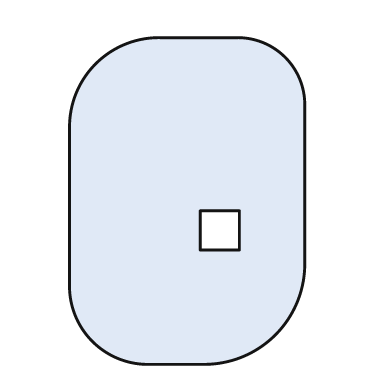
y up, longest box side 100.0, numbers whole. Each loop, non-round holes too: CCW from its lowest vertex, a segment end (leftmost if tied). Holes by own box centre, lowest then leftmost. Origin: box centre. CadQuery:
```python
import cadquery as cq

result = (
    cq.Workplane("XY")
    .moveTo(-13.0, -50.0)
    .lineTo(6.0, -50.0)
    .threePointArc((27.0, -41.0), (36.0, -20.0))
    .lineTo(36.0, 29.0)
    .threePointArc((30.0, 44.0), (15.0, 50.0))
    .lineTo(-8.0, 50.0)
    .threePointArc((-28.0, 42.0), (-36.0, 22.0))
    .lineTo(-36.0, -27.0)
    .threePointArc((-29.0, -43.0), (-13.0, -50.0))
    .close()
    .moveTo(4.0, -15.0)
    .lineTo(16.0, -15.0)
    .lineTo(16.0, -3.0)
    .lineTo(4.0, -3.0)
    .close()
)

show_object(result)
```